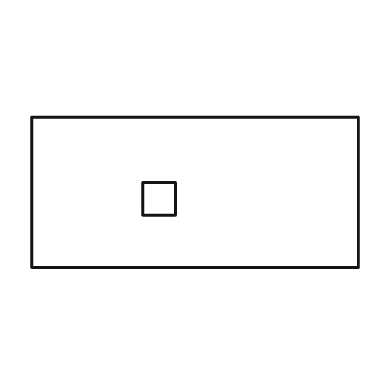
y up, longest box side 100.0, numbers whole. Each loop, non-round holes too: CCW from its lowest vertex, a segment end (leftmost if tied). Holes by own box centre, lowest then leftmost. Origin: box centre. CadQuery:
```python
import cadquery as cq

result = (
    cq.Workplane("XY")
    .moveTo(-50.0, -23.0)
    .lineTo(50.0, -23.0)
    .lineTo(50.0, 23.0)
    .lineTo(-50.0, 23.0)
    .close()
    .moveTo(-16.0, -7.0)
    .lineTo(-6.0, -7.0)
    .lineTo(-6.0, 3.0)
    .lineTo(-16.0, 3.0)
    .close()
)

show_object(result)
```